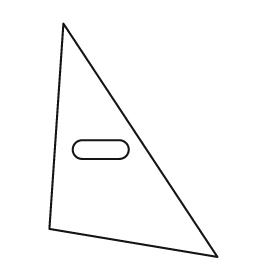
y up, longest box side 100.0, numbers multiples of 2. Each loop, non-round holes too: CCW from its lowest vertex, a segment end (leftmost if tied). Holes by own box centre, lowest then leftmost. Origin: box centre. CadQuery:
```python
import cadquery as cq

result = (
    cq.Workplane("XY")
    .moveTo(36.0, -50.0)
    .lineTo(-30.0, 50.0)
    .lineTo(-36.0, -38.0)
    .close()
    .moveTo(-22.0, -8.0)
    .lineTo(-6.0, -8.0)
    .threePointArc((-2.0, -4.0), (-6.0, 0.0))
    .lineTo(-22.0, 0.0)
    .threePointArc((-26.0, -4.0), (-22.0, -8.0))
    .close()
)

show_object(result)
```